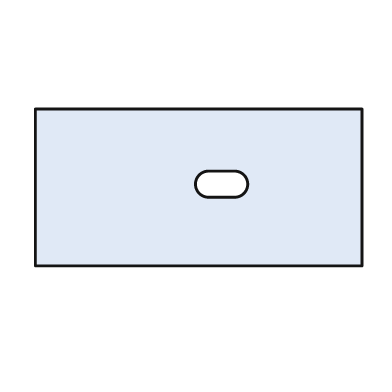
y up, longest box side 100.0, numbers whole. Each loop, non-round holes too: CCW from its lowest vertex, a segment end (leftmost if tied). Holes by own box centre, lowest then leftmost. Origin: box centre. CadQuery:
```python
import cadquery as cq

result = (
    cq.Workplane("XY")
    .moveTo(-50.0, -24.0)
    .lineTo(50.0, -24.0)
    .lineTo(50.0, 24.0)
    .lineTo(-50.0, 24.0)
    .close()
    .moveTo(3.0, -3.0)
    .lineTo(11.0, -3.0)
    .threePointArc((15.0, 1.0), (11.0, 5.0))
    .lineTo(3.0, 5.0)
    .threePointArc((-1.0, 1.0), (3.0, -3.0))
    .close()
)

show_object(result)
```